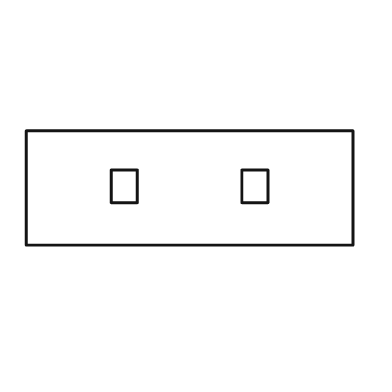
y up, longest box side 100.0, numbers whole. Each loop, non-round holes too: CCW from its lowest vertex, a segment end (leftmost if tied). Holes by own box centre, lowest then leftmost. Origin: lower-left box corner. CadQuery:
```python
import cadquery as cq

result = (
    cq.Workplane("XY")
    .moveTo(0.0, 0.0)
    .lineTo(100.0, 0.0)
    .lineTo(100.0, 35.0)
    .lineTo(0.0, 35.0)
    .close()
    .moveTo(26.0, 13.0)
    .lineTo(34.0, 13.0)
    .lineTo(34.0, 23.0)
    .lineTo(26.0, 23.0)
    .close()
    .moveTo(66.0, 13.0)
    .lineTo(74.0, 13.0)
    .lineTo(74.0, 23.0)
    .lineTo(66.0, 23.0)
    .close()
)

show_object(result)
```